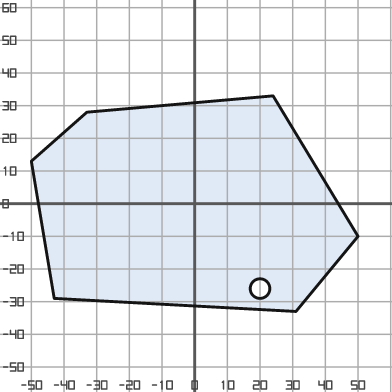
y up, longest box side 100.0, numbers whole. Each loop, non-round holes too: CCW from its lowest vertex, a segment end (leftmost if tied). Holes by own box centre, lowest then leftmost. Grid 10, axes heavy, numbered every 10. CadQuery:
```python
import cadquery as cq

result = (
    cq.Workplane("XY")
    .moveTo(31.0, -33.0)
    .lineTo(50.0, -10.0)
    .lineTo(24.0, 33.0)
    .lineTo(-33.0, 28.0)
    .lineTo(-50.0, 13.0)
    .lineTo(-43.0, -29.0)
    .close()
    .moveTo(20.0, -26.0)
    .circle(3.0)
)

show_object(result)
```